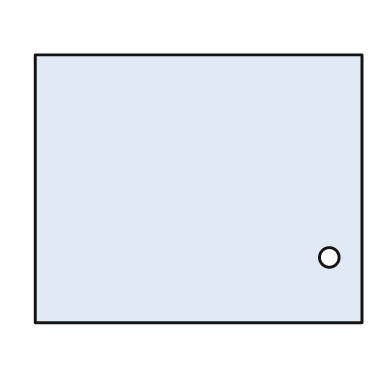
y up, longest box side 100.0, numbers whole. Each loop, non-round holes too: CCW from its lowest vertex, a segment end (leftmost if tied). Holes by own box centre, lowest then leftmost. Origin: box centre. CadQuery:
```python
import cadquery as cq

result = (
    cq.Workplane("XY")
    .moveTo(-50.0, -41.0)
    .lineTo(50.0, -41.0)
    .lineTo(50.0, 41.0)
    .lineTo(-50.0, 41.0)
    .close()
    .moveTo(40.0, -21.0)
    .circle(3.0)
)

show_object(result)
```